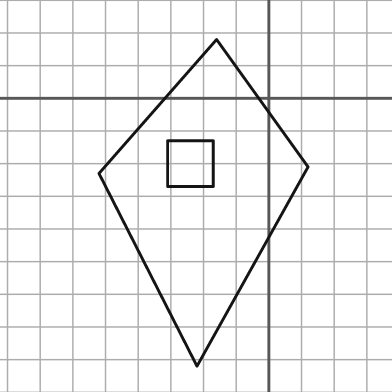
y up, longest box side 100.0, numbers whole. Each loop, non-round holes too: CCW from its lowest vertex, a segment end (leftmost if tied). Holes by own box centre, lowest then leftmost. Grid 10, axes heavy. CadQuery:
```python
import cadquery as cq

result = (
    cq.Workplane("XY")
    .moveTo(-22.0, -82.0)
    .lineTo(12.0, -21.0)
    .lineTo(-16.0, 18.0)
    .lineTo(-52.0, -23.0)
    .close()
    .moveTo(-31.0, -27.0)
    .lineTo(-17.0, -27.0)
    .lineTo(-17.0, -13.0)
    .lineTo(-31.0, -13.0)
    .close()
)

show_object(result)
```